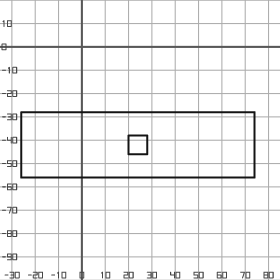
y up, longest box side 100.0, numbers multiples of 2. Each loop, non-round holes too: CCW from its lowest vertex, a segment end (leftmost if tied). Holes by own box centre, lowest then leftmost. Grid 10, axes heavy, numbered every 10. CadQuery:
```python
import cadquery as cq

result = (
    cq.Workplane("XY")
    .moveTo(-26.0, -56.0)
    .lineTo(74.0, -56.0)
    .lineTo(74.0, -28.0)
    .lineTo(-26.0, -28.0)
    .close()
    .moveTo(20.0, -46.0)
    .lineTo(28.0, -46.0)
    .lineTo(28.0, -38.0)
    .lineTo(20.0, -38.0)
    .close()
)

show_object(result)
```